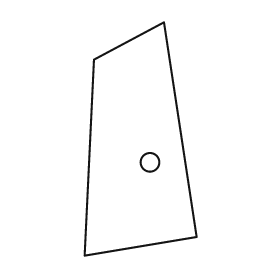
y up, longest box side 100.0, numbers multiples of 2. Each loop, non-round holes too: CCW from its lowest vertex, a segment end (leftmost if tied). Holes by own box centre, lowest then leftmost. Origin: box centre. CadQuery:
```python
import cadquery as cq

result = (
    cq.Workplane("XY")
    .moveTo(-24.0, -50.0)
    .lineTo(24.0, -42.0)
    .lineTo(10.0, 50.0)
    .lineTo(-20.0, 34.0)
    .close()
    .moveTo(4.0, -10.0)
    .circle(4.0)
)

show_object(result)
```